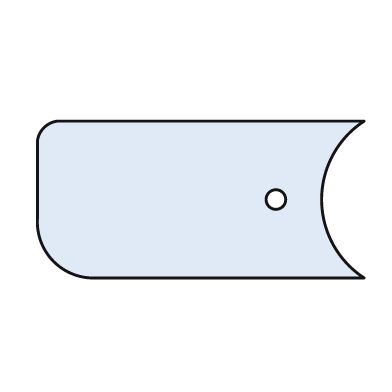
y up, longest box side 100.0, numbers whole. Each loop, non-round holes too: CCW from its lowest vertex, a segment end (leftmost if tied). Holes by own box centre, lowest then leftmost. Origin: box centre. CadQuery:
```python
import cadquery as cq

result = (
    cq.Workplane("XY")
    .moveTo(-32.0, -24.0)
    .lineTo(50.0, -24.0)
    .threePointArc((37.0, 0.0), (50.0, 24.0))
    .lineTo(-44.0, 24.0)
    .threePointArc((-48.0, 22.0), (-50.0, 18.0))
    .lineTo(-50.0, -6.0)
    .threePointArc((-45.0, -19.0), (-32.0, -24.0))
    .close()
    .moveTo(23.0, 0.0)
    .circle(3.0)
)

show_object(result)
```